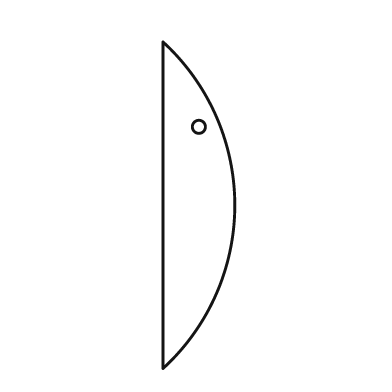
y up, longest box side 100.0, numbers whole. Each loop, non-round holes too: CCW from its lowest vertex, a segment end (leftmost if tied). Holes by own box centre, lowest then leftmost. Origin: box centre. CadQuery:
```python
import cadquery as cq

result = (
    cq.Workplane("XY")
    .moveTo(-11.0, -50.0)
    .threePointArc((11.0, 0.0), (-11.0, 50.0))
    .close()
    .moveTo(0.0, 24.0)
    .circle(2.0)
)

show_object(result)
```